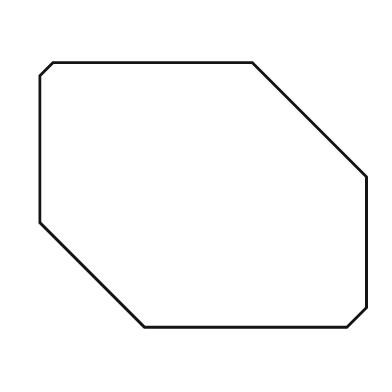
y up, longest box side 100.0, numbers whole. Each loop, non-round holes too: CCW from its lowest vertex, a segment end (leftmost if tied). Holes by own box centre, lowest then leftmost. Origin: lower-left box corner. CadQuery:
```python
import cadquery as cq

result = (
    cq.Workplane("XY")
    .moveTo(32.0, 0.0)
    .lineTo(94.0, 0.0)
    .lineTo(100.0, 6.0)
    .lineTo(100.0, 46.0)
    .lineTo(65.0, 81.0)
    .lineTo(4.0, 81.0)
    .lineTo(0.0, 77.0)
    .lineTo(0.0, 32.0)
    .close()
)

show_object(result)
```